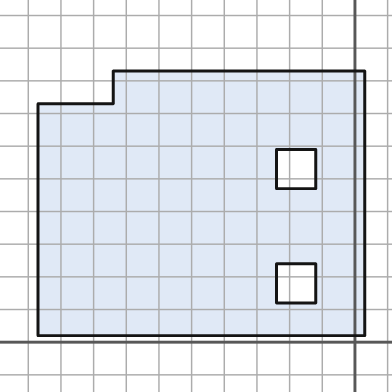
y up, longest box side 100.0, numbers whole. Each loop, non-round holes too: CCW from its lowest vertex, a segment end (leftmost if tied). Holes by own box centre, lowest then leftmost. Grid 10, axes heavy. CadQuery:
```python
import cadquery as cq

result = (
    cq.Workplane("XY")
    .moveTo(-97.0, 2.0)
    .lineTo(3.0, 2.0)
    .lineTo(3.0, 83.0)
    .lineTo(-74.0, 83.0)
    .lineTo(-74.0, 73.0)
    .lineTo(-97.0, 73.0)
    .close()
    .moveTo(-24.0, 12.0)
    .lineTo(-12.0, 12.0)
    .lineTo(-12.0, 24.0)
    .lineTo(-24.0, 24.0)
    .close()
    .moveTo(-24.0, 47.0)
    .lineTo(-12.0, 47.0)
    .lineTo(-12.0, 59.0)
    .lineTo(-24.0, 59.0)
    .close()
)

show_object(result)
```